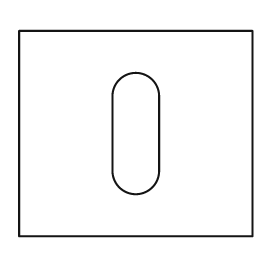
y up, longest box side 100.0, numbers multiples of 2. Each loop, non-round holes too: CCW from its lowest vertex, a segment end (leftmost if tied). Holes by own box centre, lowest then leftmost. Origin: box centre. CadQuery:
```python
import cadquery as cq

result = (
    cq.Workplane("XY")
    .moveTo(-50.0, -44.0)
    .lineTo(50.0, -44.0)
    .lineTo(50.0, 44.0)
    .lineTo(-50.0, 44.0)
    .close()
    .moveTo(-10.0, -16.0)
    .threePointArc((0.0, -26.0), (10.0, -16.0))
    .lineTo(10.0, 16.0)
    .threePointArc((0.0, 26.0), (-10.0, 16.0))
    .close()
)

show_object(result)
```